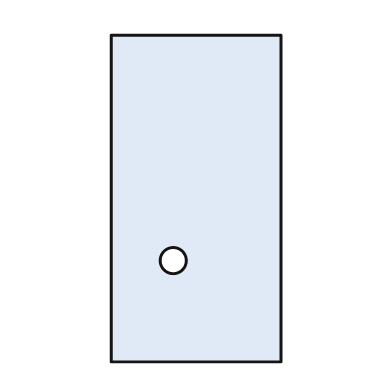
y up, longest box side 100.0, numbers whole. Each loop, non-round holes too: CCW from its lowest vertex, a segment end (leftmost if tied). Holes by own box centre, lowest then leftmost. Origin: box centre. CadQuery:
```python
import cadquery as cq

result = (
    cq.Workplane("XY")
    .moveTo(-26.0, -50.0)
    .lineTo(26.0, -50.0)
    .lineTo(26.0, 50.0)
    .lineTo(-26.0, 50.0)
    .close()
    .moveTo(-7.0, -19.0)
    .circle(4.0)
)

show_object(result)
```